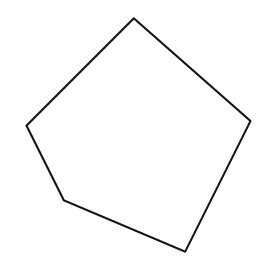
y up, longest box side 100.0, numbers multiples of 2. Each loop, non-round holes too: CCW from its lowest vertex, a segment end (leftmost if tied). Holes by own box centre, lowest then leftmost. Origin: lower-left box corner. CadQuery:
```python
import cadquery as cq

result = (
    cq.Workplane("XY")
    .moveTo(68.0, 0.0)
    .lineTo(96.0, 56.0)
    .lineTo(46.0, 100.0)
    .lineTo(0.0, 54.0)
    .lineTo(16.0, 22.0)
    .close()
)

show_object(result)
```